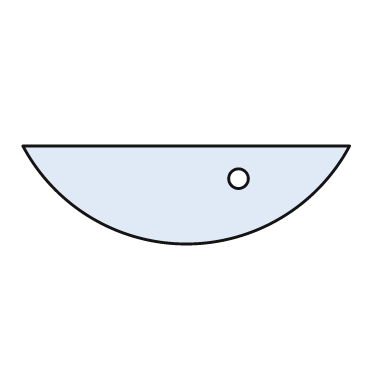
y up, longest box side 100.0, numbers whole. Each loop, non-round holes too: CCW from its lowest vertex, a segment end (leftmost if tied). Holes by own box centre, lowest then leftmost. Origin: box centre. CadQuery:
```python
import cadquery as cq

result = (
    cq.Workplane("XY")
    .moveTo(-50.0, 15.0)
    .threePointArc((0.0, -15.0), (50.0, 15.0))
    .close()
    .moveTo(16.0, 5.0)
    .circle(3.0)
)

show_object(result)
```